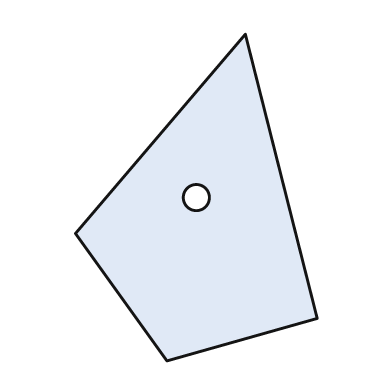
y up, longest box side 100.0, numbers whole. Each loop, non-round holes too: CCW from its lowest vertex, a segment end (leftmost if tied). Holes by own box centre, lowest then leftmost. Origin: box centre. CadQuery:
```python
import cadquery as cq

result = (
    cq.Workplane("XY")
    .moveTo(-9.0, -50.0)
    .lineTo(37.0, -37.0)
    .lineTo(15.0, 50.0)
    .lineTo(-37.0, -11.0)
    .close()
    .moveTo(0.0, 0.0)
    .circle(4.0)
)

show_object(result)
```